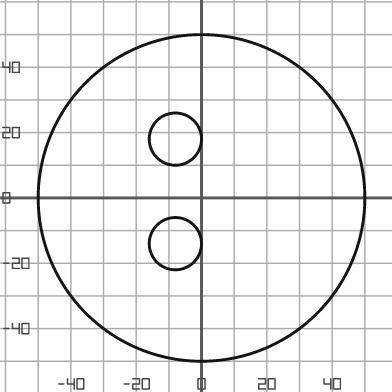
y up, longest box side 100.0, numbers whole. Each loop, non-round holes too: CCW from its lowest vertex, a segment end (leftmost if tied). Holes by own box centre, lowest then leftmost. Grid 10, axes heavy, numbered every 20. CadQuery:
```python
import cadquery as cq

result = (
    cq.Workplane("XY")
    .moveTo(0.0, 0.0)
    .circle(50.0)
    .moveTo(-8.0, -14.0)
    .circle(8.0)
    .moveTo(-8.0, 18.0)
    .circle(8.0)
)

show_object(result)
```